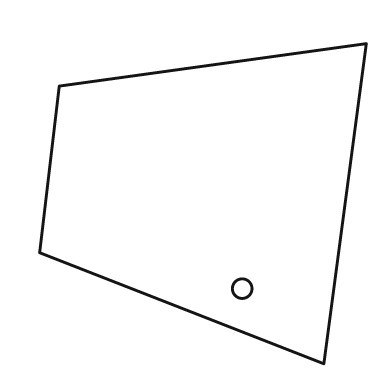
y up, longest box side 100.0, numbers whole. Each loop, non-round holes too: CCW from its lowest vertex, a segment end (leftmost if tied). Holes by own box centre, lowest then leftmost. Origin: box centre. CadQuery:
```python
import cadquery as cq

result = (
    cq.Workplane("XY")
    .moveTo(37.0, -49.0)
    .lineTo(50.0, 49.0)
    .lineTo(-44.0, 36.0)
    .lineTo(-50.0, -15.0)
    .close()
    .moveTo(12.0, -26.0)
    .circle(3.0)
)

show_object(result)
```